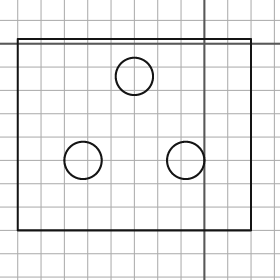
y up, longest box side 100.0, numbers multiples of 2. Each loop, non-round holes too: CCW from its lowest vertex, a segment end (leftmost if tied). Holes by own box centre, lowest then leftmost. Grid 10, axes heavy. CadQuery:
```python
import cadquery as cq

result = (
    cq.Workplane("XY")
    .moveTo(-80.0, -80.0)
    .lineTo(20.0, -80.0)
    .lineTo(20.0, 2.0)
    .lineTo(-80.0, 2.0)
    .close()
    .moveTo(-52.0, -50.0)
    .circle(8.0)
    .moveTo(-8.0, -50.0)
    .circle(8.0)
    .moveTo(-30.0, -14.0)
    .circle(8.0)
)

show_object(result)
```